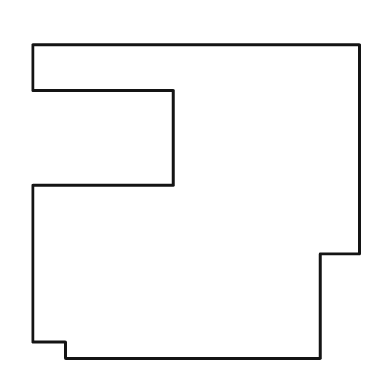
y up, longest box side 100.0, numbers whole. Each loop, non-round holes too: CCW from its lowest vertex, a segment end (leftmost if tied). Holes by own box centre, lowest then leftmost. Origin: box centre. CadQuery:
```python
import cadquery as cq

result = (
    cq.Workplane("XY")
    .moveTo(-40.0, -48.0)
    .lineTo(38.0, -48.0)
    .lineTo(38.0, -16.0)
    .lineTo(50.0, -16.0)
    .lineTo(50.0, 48.0)
    .lineTo(-50.0, 48.0)
    .lineTo(-50.0, 34.0)
    .lineTo(-7.0, 34.0)
    .lineTo(-7.0, 5.0)
    .lineTo(-50.0, 5.0)
    .lineTo(-50.0, -43.0)
    .lineTo(-40.0, -43.0)
    .close()
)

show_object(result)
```